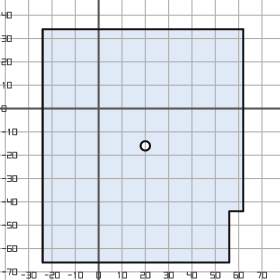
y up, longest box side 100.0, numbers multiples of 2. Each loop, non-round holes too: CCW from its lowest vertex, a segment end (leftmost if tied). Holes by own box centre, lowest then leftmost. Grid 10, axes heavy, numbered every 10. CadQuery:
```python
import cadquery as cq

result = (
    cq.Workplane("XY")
    .moveTo(-24.0, -66.0)
    .lineTo(56.0, -66.0)
    .lineTo(56.0, -44.0)
    .lineTo(62.0, -44.0)
    .lineTo(62.0, 34.0)
    .lineTo(-24.0, 34.0)
    .close()
    .moveTo(20.0, -16.0)
    .circle(2.0)
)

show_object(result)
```